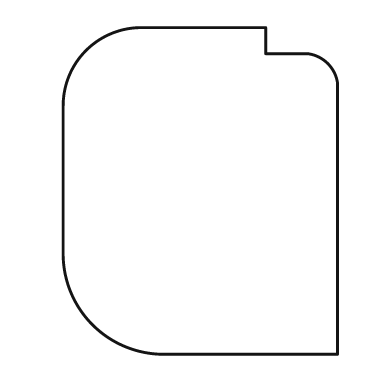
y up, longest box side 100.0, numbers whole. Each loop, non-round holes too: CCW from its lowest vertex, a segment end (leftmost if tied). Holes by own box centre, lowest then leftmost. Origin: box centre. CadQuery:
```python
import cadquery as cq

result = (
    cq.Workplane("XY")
    .moveTo(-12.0, -50.0)
    .lineTo(42.0, -50.0)
    .lineTo(42.0, 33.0)
    .threePointArc((39.0, 39.0), (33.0, 42.0))
    .lineTo(20.0, 42.0)
    .lineTo(20.0, 50.0)
    .lineTo(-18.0, 50.0)
    .threePointArc((-35.0, 43.0), (-42.0, 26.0))
    .lineTo(-42.0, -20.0)
    .threePointArc((-33.0, -41.0), (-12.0, -50.0))
    .close()
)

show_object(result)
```